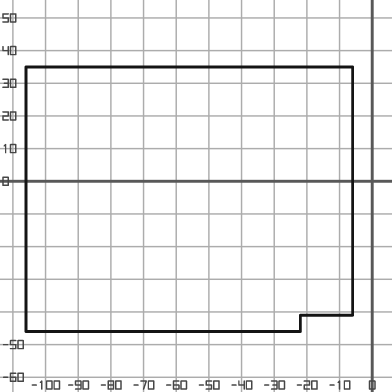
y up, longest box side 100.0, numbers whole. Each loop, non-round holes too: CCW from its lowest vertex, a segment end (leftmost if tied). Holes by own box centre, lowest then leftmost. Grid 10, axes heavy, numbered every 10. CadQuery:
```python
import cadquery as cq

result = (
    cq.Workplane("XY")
    .moveTo(-106.0, -46.0)
    .lineTo(-22.0, -46.0)
    .lineTo(-22.0, -41.0)
    .lineTo(-6.0, -41.0)
    .lineTo(-6.0, 35.0)
    .lineTo(-106.0, 35.0)
    .close()
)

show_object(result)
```